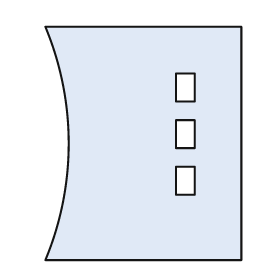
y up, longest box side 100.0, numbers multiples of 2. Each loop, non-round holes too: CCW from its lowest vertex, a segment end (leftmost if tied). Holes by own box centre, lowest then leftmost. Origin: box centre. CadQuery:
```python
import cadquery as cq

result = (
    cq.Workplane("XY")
    .moveTo(-42.0, -50.0)
    .lineTo(42.0, -50.0)
    .lineTo(42.0, 50.0)
    .lineTo(-42.0, 50.0)
    .threePointArc((-32.0, 0.0), (-42.0, -50.0))
    .close()
    .moveTo(14.0, -22.0)
    .lineTo(22.0, -22.0)
    .lineTo(22.0, -10.0)
    .lineTo(14.0, -10.0)
    .close()
    .moveTo(14.0, -2.0)
    .lineTo(22.0, -2.0)
    .lineTo(22.0, 10.0)
    .lineTo(14.0, 10.0)
    .close()
    .moveTo(14.0, 18.0)
    .lineTo(22.0, 18.0)
    .lineTo(22.0, 30.0)
    .lineTo(14.0, 30.0)
    .close()
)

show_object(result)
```